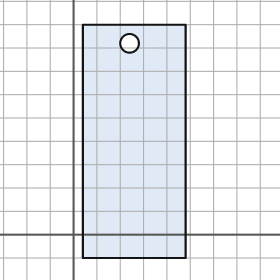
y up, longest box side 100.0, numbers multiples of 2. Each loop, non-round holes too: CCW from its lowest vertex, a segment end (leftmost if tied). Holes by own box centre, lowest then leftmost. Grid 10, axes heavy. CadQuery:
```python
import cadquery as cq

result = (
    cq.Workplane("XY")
    .moveTo(4.0, -10.0)
    .lineTo(48.0, -10.0)
    .lineTo(48.0, 90.0)
    .lineTo(4.0, 90.0)
    .close()
    .moveTo(24.0, 82.0)
    .circle(4.0)
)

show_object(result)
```